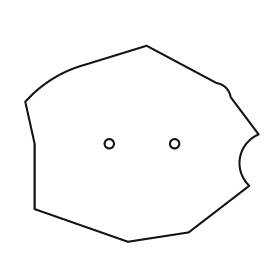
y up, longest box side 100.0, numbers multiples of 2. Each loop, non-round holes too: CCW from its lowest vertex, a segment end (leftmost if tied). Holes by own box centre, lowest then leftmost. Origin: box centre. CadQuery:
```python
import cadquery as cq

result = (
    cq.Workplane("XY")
    .moveTo(-6.0, -42.0)
    .lineTo(20.0, -38.0)
    .lineTo(46.0, -18.0)
    .threePointArc((42.0, -6.0), (50.0, 4.0))
    .lineTo(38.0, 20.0)
    .threePointArc((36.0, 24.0), (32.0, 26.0))
    .lineTo(2.0, 42.0)
    .lineTo(-24.0, 34.0)
    .threePointArc((-38.0, 28.0), (-50.0, 18.0))
    .lineTo(-46.0, 0.0)
    .lineTo(-46.0, -28.0)
    .close()
    .moveTo(-14.0, 0.0)
    .circle(2.0)
    .moveTo(14.0, 0.0)
    .circle(2.0)
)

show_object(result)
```